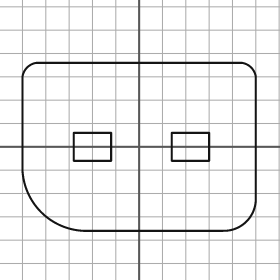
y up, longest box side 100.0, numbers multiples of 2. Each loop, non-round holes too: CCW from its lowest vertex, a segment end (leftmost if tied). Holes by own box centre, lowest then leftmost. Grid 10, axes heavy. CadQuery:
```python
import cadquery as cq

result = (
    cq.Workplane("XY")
    .moveTo(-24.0, -36.0)
    .lineTo(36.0, -36.0)
    .threePointArc((46.0, -32.0), (50.0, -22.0))
    .lineTo(50.0, 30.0)
    .threePointArc((48.0, 34.0), (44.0, 36.0))
    .lineTo(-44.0, 36.0)
    .threePointArc((-48.0, 34.0), (-50.0, 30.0))
    .lineTo(-50.0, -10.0)
    .threePointArc((-42.0, -28.0), (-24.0, -36.0))
    .close()
    .moveTo(-28.0, -6.0)
    .lineTo(-12.0, -6.0)
    .lineTo(-12.0, 6.0)
    .lineTo(-28.0, 6.0)
    .close()
    .moveTo(14.0, -6.0)
    .lineTo(30.0, -6.0)
    .lineTo(30.0, 6.0)
    .lineTo(14.0, 6.0)
    .close()
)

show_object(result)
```